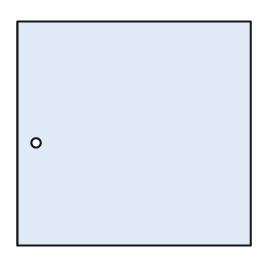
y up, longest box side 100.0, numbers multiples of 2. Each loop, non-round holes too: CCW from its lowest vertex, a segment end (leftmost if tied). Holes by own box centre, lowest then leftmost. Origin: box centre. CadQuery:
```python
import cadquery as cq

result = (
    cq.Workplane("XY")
    .moveTo(-50.0, -48.0)
    .lineTo(50.0, -48.0)
    .lineTo(50.0, 48.0)
    .lineTo(-50.0, 48.0)
    .close()
    .moveTo(-42.0, -4.0)
    .circle(2.0)
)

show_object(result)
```